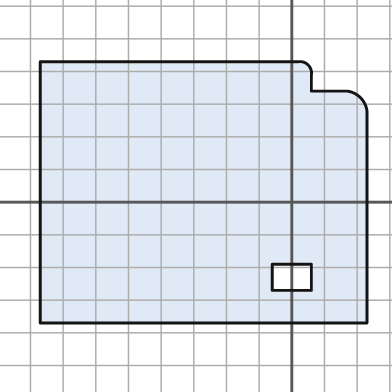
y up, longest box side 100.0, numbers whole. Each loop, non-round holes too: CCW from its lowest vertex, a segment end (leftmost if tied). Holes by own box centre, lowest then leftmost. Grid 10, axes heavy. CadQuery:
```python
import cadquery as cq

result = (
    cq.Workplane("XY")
    .moveTo(-77.0, -37.0)
    .lineTo(23.0, -37.0)
    .lineTo(23.0, 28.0)
    .threePointArc((21.0, 32.0), (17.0, 34.0))
    .lineTo(6.0, 34.0)
    .lineTo(6.0, 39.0)
    .threePointArc((5.0, 42.0), (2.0, 43.0))
    .lineTo(-77.0, 43.0)
    .close()
    .moveTo(-6.0, -27.0)
    .lineTo(6.0, -27.0)
    .lineTo(6.0, -19.0)
    .lineTo(-6.0, -19.0)
    .close()
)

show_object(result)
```